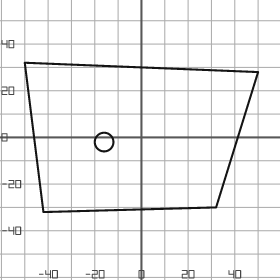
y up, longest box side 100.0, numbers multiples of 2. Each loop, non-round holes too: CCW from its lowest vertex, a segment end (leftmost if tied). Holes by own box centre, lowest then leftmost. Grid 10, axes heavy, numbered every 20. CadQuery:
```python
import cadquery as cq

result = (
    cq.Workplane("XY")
    .moveTo(-42.0, -32.0)
    .lineTo(32.0, -30.0)
    .lineTo(50.0, 28.0)
    .lineTo(-50.0, 32.0)
    .close()
    .moveTo(-16.0, -2.0)
    .circle(4.0)
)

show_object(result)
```